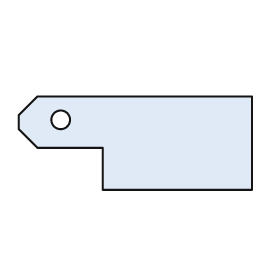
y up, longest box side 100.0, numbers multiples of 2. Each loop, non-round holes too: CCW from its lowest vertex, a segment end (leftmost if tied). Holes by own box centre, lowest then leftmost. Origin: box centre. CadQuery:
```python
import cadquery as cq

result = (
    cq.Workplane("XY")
    .moveTo(-14.0, -20.0)
    .lineTo(50.0, -20.0)
    .lineTo(50.0, 20.0)
    .lineTo(-42.0, 20.0)
    .lineTo(-50.0, 12.0)
    .lineTo(-50.0, 6.0)
    .lineTo(-42.0, -2.0)
    .lineTo(-14.0, -2.0)
    .close()
    .moveTo(-32.0, 10.0)
    .circle(4.0)
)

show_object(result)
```